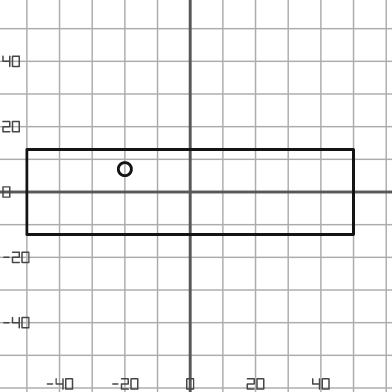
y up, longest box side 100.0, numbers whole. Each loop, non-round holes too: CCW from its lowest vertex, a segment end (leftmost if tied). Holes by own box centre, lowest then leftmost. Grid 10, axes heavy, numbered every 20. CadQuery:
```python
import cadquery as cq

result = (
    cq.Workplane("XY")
    .moveTo(-50.0, -13.0)
    .lineTo(50.0, -13.0)
    .lineTo(50.0, 13.0)
    .lineTo(-50.0, 13.0)
    .close()
    .moveTo(-20.0, 7.0)
    .circle(2.0)
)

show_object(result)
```